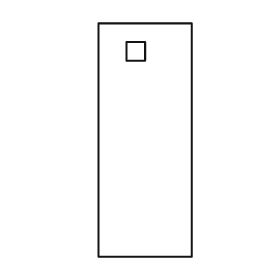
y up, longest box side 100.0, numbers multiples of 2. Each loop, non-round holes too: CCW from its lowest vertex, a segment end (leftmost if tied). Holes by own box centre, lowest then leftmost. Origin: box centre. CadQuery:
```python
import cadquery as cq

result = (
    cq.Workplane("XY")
    .moveTo(-20.0, -50.0)
    .lineTo(20.0, -50.0)
    .lineTo(20.0, 50.0)
    .lineTo(-20.0, 50.0)
    .close()
    .moveTo(-8.0, 34.0)
    .lineTo(0.0, 34.0)
    .lineTo(0.0, 42.0)
    .lineTo(-8.0, 42.0)
    .close()
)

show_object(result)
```